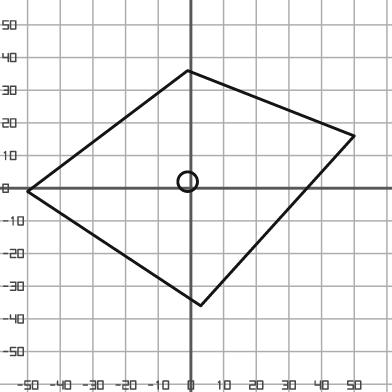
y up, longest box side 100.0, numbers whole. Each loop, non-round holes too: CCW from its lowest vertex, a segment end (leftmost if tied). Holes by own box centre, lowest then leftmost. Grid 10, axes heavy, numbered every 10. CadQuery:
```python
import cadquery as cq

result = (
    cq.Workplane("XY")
    .moveTo(3.0, -36.0)
    .lineTo(50.0, 16.0)
    .lineTo(-1.0, 36.0)
    .lineTo(-50.0, -1.0)
    .close()
    .moveTo(-1.0, 2.0)
    .circle(3.0)
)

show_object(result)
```